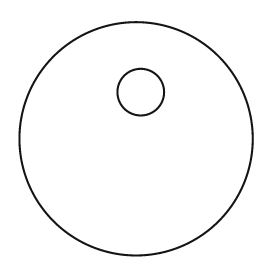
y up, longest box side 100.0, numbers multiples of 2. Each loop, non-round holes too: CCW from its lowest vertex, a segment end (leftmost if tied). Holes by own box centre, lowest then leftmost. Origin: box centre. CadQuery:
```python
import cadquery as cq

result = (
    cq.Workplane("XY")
    .moveTo(0.0, 0.0)
    .circle(50.0)
    .moveTo(2.0, 20.0)
    .circle(10.0)
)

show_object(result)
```